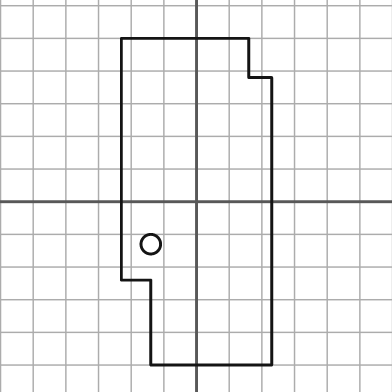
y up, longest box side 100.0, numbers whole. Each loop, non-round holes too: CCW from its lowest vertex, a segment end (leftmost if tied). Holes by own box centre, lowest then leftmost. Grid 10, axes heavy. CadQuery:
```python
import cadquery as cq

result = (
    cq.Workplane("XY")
    .moveTo(-14.0, -50.0)
    .lineTo(23.0, -50.0)
    .lineTo(23.0, 38.0)
    .lineTo(16.0, 38.0)
    .lineTo(16.0, 50.0)
    .lineTo(-23.0, 50.0)
    .lineTo(-23.0, -24.0)
    .lineTo(-14.0, -24.0)
    .close()
    .moveTo(-14.0, -13.0)
    .circle(3.0)
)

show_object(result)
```